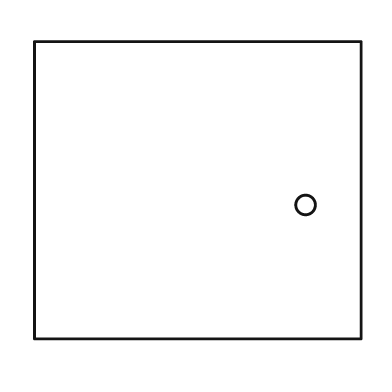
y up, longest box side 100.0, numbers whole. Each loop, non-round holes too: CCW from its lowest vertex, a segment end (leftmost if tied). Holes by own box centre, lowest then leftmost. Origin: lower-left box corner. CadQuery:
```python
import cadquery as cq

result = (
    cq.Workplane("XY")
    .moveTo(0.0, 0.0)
    .lineTo(100.0, 0.0)
    .lineTo(100.0, 91.0)
    .lineTo(0.0, 91.0)
    .close()
    .moveTo(83.0, 41.0)
    .circle(3.0)
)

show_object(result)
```